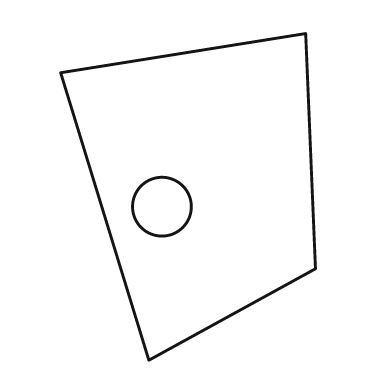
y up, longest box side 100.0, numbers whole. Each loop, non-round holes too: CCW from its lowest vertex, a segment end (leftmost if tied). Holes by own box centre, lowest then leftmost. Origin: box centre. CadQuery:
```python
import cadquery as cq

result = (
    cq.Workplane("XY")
    .moveTo(-12.0, -50.0)
    .lineTo(39.0, -22.0)
    .lineTo(36.0, 50.0)
    .lineTo(-39.0, 38.0)
    .close()
    .moveTo(-8.0, -3.0)
    .circle(9.0)
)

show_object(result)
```